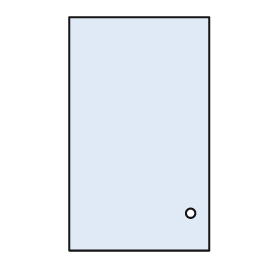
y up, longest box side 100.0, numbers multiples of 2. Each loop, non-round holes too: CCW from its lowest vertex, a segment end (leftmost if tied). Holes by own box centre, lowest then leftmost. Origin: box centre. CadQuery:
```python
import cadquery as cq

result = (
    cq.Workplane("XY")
    .moveTo(-30.0, -50.0)
    .lineTo(30.0, -50.0)
    .lineTo(30.0, 50.0)
    .lineTo(-30.0, 50.0)
    .close()
    .moveTo(22.0, -34.0)
    .circle(2.0)
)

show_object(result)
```